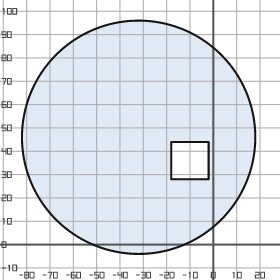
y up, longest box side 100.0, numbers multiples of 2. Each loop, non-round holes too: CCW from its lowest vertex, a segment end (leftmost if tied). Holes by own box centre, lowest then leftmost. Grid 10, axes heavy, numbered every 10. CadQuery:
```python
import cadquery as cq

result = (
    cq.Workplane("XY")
    .moveTo(-32.0, 46.0)
    .circle(50.0)
    .moveTo(-18.0, 28.0)
    .lineTo(-2.0, 28.0)
    .lineTo(-2.0, 44.0)
    .lineTo(-18.0, 44.0)
    .close()
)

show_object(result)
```